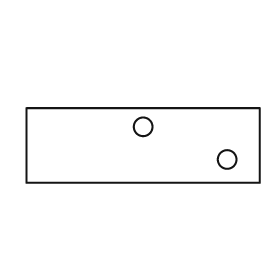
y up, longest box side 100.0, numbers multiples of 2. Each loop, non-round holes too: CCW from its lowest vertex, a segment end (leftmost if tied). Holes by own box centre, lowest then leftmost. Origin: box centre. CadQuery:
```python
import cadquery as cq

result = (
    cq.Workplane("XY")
    .moveTo(-50.0, -16.0)
    .lineTo(50.0, -16.0)
    .lineTo(50.0, 16.0)
    .lineTo(-50.0, 16.0)
    .close()
    .moveTo(36.0, -6.0)
    .circle(4.0)
    .moveTo(0.0, 8.0)
    .circle(4.0)
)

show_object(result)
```